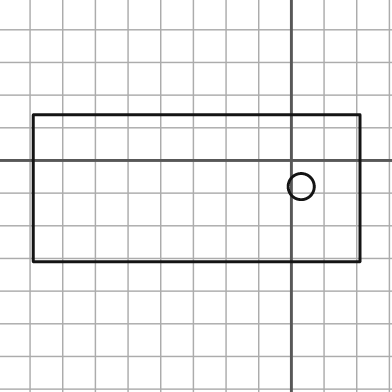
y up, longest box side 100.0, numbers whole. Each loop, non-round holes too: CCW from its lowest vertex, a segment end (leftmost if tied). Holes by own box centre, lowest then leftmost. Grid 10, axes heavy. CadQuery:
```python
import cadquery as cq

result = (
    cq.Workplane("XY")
    .moveTo(-79.0, -31.0)
    .lineTo(21.0, -31.0)
    .lineTo(21.0, 14.0)
    .lineTo(-79.0, 14.0)
    .close()
    .moveTo(3.0, -8.0)
    .circle(4.0)
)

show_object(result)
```